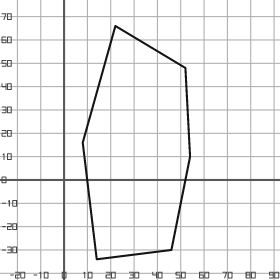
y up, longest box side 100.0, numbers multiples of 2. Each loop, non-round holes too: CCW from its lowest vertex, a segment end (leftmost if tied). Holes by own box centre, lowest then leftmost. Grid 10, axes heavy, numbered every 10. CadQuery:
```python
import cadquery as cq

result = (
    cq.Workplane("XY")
    .moveTo(14.0, -34.0)
    .lineTo(46.0, -30.0)
    .lineTo(54.0, 10.0)
    .lineTo(52.0, 48.0)
    .lineTo(22.0, 66.0)
    .lineTo(8.0, 16.0)
    .close()
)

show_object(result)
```